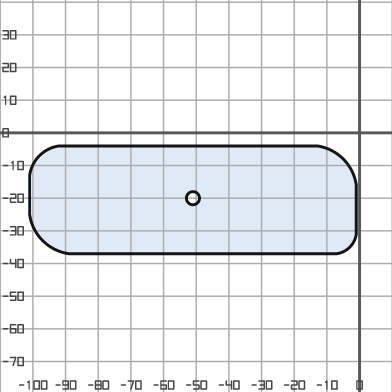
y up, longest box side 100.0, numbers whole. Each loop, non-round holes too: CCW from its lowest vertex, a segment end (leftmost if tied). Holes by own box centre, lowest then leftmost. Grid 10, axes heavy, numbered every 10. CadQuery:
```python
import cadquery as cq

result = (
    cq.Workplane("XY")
    .moveTo(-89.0, -37.0)
    .lineTo(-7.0, -37.0)
    .threePointArc((-3.0, -35.0), (-1.0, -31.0))
    .lineTo(-1.0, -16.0)
    .threePointArc((-5.0, -8.0), (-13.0, -4.0))
    .lineTo(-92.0, -4.0)
    .threePointArc((-98.0, -7.0), (-101.0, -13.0))
    .lineTo(-101.0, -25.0)
    .threePointArc((-97.0, -33.0), (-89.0, -37.0))
    .close()
    .moveTo(-51.0, -20.0)
    .circle(2.0)
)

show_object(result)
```